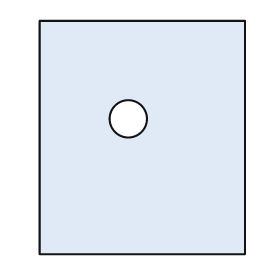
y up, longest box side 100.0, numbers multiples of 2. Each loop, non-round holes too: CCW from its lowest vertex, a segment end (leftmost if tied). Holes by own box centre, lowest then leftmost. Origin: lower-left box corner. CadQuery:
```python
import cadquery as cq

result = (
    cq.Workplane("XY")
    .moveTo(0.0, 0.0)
    .lineTo(88.0, 0.0)
    .lineTo(88.0, 100.0)
    .lineTo(0.0, 100.0)
    .close()
    .moveTo(38.0, 58.0)
    .circle(8.0)
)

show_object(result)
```